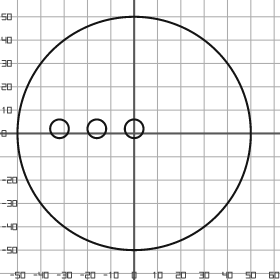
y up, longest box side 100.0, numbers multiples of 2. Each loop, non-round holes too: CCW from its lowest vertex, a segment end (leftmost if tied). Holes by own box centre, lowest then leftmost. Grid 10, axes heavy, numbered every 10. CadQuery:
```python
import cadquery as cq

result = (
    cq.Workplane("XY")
    .moveTo(0.0, 0.0)
    .circle(50.0)
    .moveTo(-32.0, 2.0)
    .circle(4.0)
    .moveTo(-16.0, 2.0)
    .circle(4.0)
    .moveTo(0.0, 2.0)
    .circle(4.0)
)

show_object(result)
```